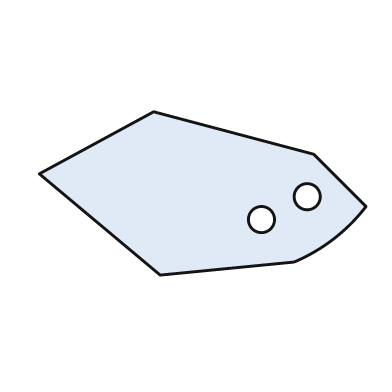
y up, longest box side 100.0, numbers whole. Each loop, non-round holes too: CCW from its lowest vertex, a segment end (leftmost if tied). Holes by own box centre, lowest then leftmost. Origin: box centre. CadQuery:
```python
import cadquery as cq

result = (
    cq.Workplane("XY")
    .moveTo(-13.0, -25.0)
    .lineTo(28.0, -21.0)
    .threePointArc((40.0, -14.0), (50.0, -4.0))
    .lineTo(34.0, 12.0)
    .lineTo(-15.0, 25.0)
    .lineTo(-50.0, 6.0)
    .close()
    .moveTo(18.0, -8.0)
    .circle(4.0)
    .moveTo(32.0, -1.0)
    .circle(4.0)
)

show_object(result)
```